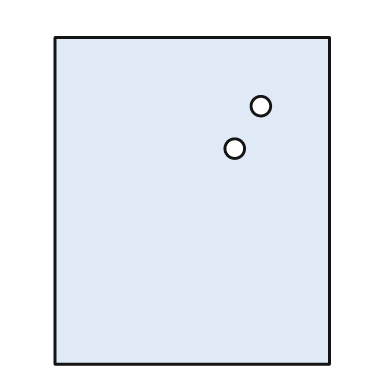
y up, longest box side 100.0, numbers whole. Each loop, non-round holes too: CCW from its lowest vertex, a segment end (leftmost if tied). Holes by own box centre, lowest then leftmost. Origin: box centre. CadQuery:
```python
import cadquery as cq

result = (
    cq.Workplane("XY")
    .moveTo(-42.0, -50.0)
    .lineTo(42.0, -50.0)
    .lineTo(42.0, 50.0)
    .lineTo(-42.0, 50.0)
    .close()
    .moveTo(13.0, 16.0)
    .circle(3.0)
    .moveTo(21.0, 29.0)
    .circle(3.0)
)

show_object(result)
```